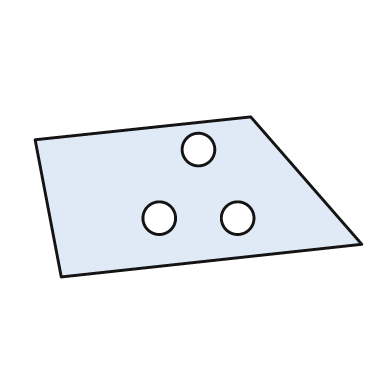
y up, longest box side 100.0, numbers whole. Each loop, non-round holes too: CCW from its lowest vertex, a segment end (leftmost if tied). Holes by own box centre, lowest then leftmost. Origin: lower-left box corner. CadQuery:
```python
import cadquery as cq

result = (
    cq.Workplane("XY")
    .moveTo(8.0, 0.0)
    .lineTo(100.0, 10.0)
    .lineTo(66.0, 49.0)
    .lineTo(0.0, 42.0)
    .close()
    .moveTo(38.0, 18.0)
    .circle(5.0)
    .moveTo(62.0, 18.0)
    .circle(5.0)
    .moveTo(50.0, 39.0)
    .circle(5.0)
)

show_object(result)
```